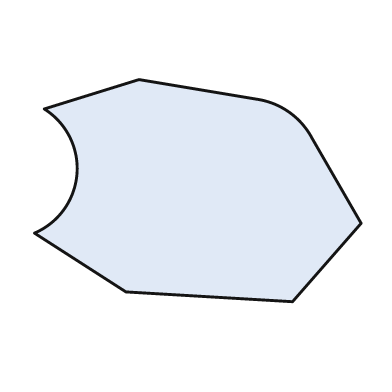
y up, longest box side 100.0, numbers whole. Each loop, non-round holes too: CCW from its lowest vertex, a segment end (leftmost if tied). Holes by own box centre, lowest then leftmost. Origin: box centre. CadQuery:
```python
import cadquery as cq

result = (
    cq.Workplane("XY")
    .moveTo(29.0, -34.0)
    .lineTo(50.0, -10.0)
    .lineTo(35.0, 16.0)
    .threePointArc((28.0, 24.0), (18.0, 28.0))
    .lineTo(-18.0, 34.0)
    .lineTo(-47.0, 25.0)
    .threePointArc((-37.0, 5.0), (-50.0, -13.0))
    .lineTo(-22.0, -31.0)
    .close()
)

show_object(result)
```